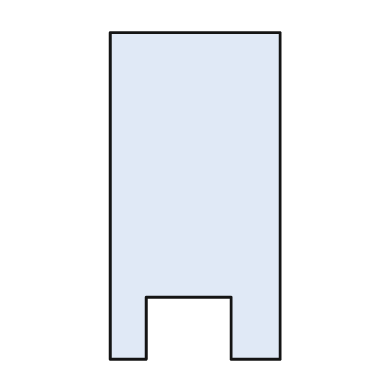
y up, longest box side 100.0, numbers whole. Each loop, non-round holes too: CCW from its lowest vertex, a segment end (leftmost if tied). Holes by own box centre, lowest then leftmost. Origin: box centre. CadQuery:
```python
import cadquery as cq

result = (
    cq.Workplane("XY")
    .moveTo(-26.0, -50.0)
    .lineTo(-15.0, -50.0)
    .lineTo(-15.0, -31.0)
    .lineTo(11.0, -31.0)
    .lineTo(11.0, -50.0)
    .lineTo(26.0, -50.0)
    .lineTo(26.0, 50.0)
    .lineTo(-26.0, 50.0)
    .close()
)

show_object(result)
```